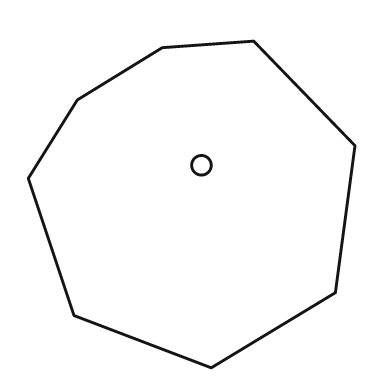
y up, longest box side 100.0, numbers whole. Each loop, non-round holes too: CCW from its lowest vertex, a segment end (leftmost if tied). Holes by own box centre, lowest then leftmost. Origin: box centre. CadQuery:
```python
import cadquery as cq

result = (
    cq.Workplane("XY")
    .moveTo(6.0, -50.0)
    .lineTo(44.0, -27.0)
    .lineTo(50.0, 18.0)
    .lineTo(19.0, 50.0)
    .lineTo(-9.0, 48.0)
    .lineTo(-35.0, 32.0)
    .lineTo(-50.0, 8.0)
    .lineTo(-36.0, -34.0)
    .close()
    .moveTo(3.0, 12.0)
    .circle(3.0)
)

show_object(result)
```